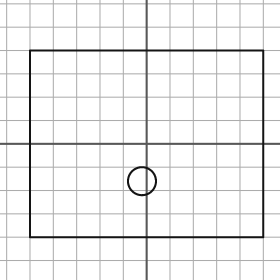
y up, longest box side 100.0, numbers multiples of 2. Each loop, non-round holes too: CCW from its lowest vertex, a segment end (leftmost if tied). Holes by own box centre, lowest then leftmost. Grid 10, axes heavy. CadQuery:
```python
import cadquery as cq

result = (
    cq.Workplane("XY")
    .moveTo(-50.0, -40.0)
    .lineTo(50.0, -40.0)
    .lineTo(50.0, 40.0)
    .lineTo(-50.0, 40.0)
    .close()
    .moveTo(-2.0, -16.0)
    .circle(6.0)
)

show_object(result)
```